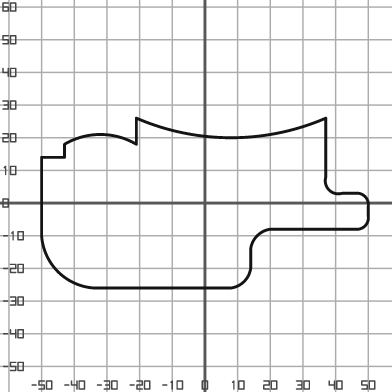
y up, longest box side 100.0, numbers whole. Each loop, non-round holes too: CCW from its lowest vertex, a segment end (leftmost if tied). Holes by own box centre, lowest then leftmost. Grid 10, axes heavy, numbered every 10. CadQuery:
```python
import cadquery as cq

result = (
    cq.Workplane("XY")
    .moveTo(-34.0, -26.0)
    .lineTo(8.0, -26.0)
    .threePointArc((12.0, -24.0), (14.0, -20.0))
    .lineTo(14.0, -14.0)
    .threePointArc((16.0, -10.0), (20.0, -8.0))
    .lineTo(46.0, -8.0)
    .threePointArc((49.0, -7.0), (50.0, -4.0))
    .lineTo(50.0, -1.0)
    .threePointArc((49.0, 2.0), (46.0, 3.0))
    .lineTo(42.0, 3.0)
    .threePointArc((38.0, 4.0), (37.0, 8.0))
    .lineTo(37.0, 26.0)
    .threePointArc((8.0, 20.0), (-21.0, 26.0))
    .lineTo(-21.0, 18.0)
    .threePointArc((-32.0, 21.0), (-43.0, 18.0))
    .lineTo(-43.0, 14.0)
    .lineTo(-50.0, 14.0)
    .lineTo(-50.0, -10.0)
    .threePointArc((-45.0, -21.0), (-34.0, -26.0))
    .close()
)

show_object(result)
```